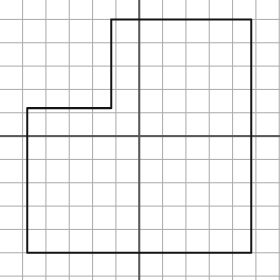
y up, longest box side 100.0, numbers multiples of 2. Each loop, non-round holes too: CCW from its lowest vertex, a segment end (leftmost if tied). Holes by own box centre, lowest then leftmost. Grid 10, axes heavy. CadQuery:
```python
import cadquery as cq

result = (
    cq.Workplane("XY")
    .moveTo(-48.0, -50.0)
    .lineTo(48.0, -50.0)
    .lineTo(48.0, 50.0)
    .lineTo(-12.0, 50.0)
    .lineTo(-12.0, 12.0)
    .lineTo(-48.0, 12.0)
    .close()
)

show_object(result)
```